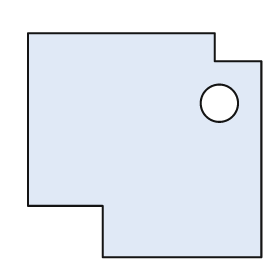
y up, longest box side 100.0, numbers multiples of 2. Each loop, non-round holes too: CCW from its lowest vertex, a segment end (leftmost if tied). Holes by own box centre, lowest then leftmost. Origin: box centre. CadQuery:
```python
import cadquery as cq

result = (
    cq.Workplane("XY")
    .moveTo(-18.0, -48.0)
    .lineTo(50.0, -48.0)
    .lineTo(50.0, 36.0)
    .lineTo(30.0, 36.0)
    .lineTo(30.0, 48.0)
    .lineTo(-50.0, 48.0)
    .lineTo(-50.0, -26.0)
    .lineTo(-18.0, -26.0)
    .close()
    .moveTo(32.0, 18.0)
    .circle(8.0)
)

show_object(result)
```